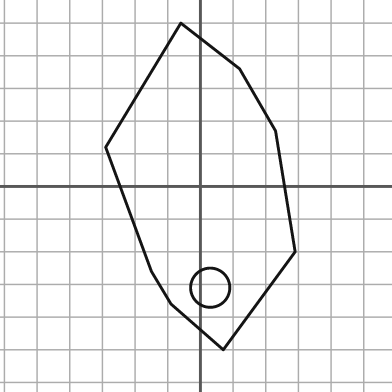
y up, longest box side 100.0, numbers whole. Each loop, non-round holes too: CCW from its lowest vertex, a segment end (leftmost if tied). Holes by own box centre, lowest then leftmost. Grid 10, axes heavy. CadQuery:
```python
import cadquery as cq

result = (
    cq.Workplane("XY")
    .moveTo(7.0, -50.0)
    .lineTo(29.0, -20.0)
    .lineTo(23.0, 17.0)
    .lineTo(12.0, 36.0)
    .lineTo(-6.0, 50.0)
    .lineTo(-29.0, 12.0)
    .lineTo(-15.0, -26.0)
    .lineTo(-9.0, -36.0)
    .close()
    .moveTo(3.0, -31.0)
    .circle(6.0)
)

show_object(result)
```